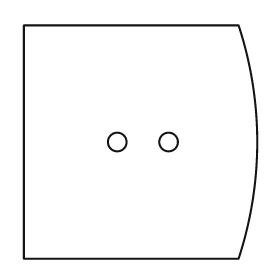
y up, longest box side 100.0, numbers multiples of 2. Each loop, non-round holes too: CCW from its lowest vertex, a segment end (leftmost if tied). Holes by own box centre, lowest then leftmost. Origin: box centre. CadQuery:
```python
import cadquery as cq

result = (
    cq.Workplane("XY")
    .moveTo(-50.0, -50.0)
    .lineTo(42.0, -50.0)
    .threePointArc((50.0, 0.0), (42.0, 50.0))
    .lineTo(-50.0, 50.0)
    .close()
    .moveTo(-10.0, 0.0)
    .circle(4.0)
    .moveTo(12.0, 0.0)
    .circle(4.0)
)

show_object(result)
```